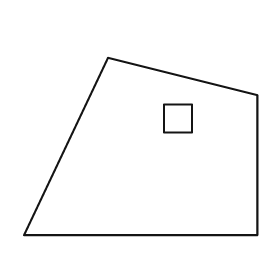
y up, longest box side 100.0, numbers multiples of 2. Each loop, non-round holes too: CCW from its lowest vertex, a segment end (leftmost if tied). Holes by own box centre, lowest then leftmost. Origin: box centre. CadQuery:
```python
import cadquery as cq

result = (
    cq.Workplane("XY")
    .moveTo(-50.0, -38.0)
    .lineTo(50.0, -38.0)
    .lineTo(50.0, 22.0)
    .lineTo(-14.0, 38.0)
    .close()
    .moveTo(10.0, 6.0)
    .lineTo(22.0, 6.0)
    .lineTo(22.0, 18.0)
    .lineTo(10.0, 18.0)
    .close()
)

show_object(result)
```